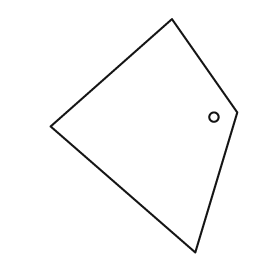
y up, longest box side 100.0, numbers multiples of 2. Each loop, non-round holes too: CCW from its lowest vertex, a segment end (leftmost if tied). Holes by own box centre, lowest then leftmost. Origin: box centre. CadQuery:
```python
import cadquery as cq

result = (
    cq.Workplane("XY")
    .moveTo(22.0, -50.0)
    .lineTo(40.0, 10.0)
    .lineTo(12.0, 50.0)
    .lineTo(-40.0, 4.0)
    .close()
    .moveTo(30.0, 8.0)
    .circle(2.0)
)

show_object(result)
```